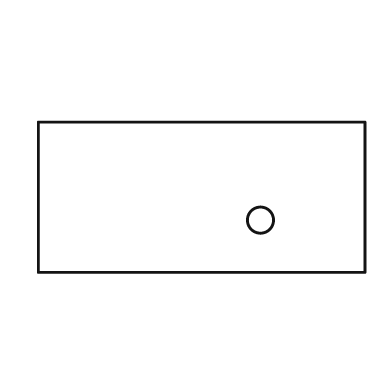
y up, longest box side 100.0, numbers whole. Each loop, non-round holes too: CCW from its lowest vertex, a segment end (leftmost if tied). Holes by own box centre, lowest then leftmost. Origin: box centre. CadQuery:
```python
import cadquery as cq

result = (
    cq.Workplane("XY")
    .moveTo(-50.0, -23.0)
    .lineTo(50.0, -23.0)
    .lineTo(50.0, 23.0)
    .lineTo(-50.0, 23.0)
    .close()
    .moveTo(18.0, -7.0)
    .circle(4.0)
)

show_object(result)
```